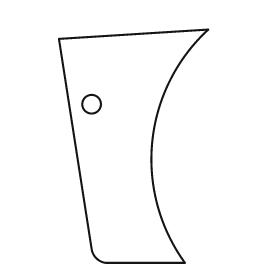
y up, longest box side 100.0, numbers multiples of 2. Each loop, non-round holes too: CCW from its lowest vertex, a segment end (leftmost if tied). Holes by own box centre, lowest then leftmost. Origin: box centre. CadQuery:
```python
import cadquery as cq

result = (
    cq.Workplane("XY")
    .moveTo(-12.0, -50.0)
    .lineTo(22.0, -50.0)
    .threePointArc((8.0, 2.0), (32.0, 50.0))
    .lineTo(-32.0, 46.0)
    .lineTo(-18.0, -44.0)
    .threePointArc((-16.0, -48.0), (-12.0, -50.0))
    .close()
    .moveTo(-18.0, 18.0)
    .circle(4.0)
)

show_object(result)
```